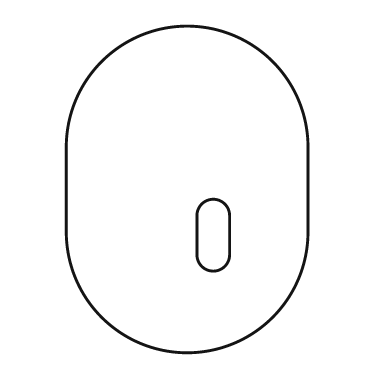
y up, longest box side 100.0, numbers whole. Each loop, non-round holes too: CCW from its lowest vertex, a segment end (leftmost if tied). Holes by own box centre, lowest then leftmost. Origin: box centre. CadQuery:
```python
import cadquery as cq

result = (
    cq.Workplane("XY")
    .moveTo(-37.0, -13.0)
    .threePointArc((0.0, -50.0), (37.0, -13.0))
    .lineTo(37.0, 13.0)
    .threePointArc((0.0, 50.0), (-37.0, 13.0))
    .close()
    .moveTo(3.0, -20.0)
    .threePointArc((8.0, -25.0), (13.0, -20.0))
    .lineTo(13.0, -8.0)
    .threePointArc((8.0, -3.0), (3.0, -8.0))
    .close()
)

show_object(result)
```